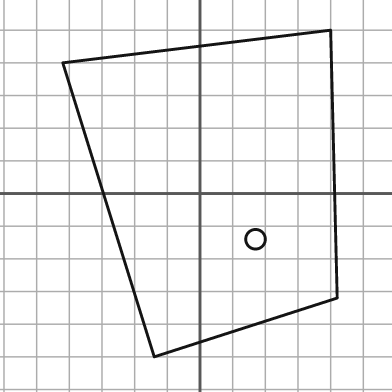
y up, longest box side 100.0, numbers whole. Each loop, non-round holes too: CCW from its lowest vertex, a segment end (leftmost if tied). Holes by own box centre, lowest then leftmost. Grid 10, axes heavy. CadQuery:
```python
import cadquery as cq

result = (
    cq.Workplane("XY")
    .moveTo(-14.0, -50.0)
    .lineTo(42.0, -32.0)
    .lineTo(40.0, 50.0)
    .lineTo(-42.0, 40.0)
    .close()
    .moveTo(17.0, -14.0)
    .circle(3.0)
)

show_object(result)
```